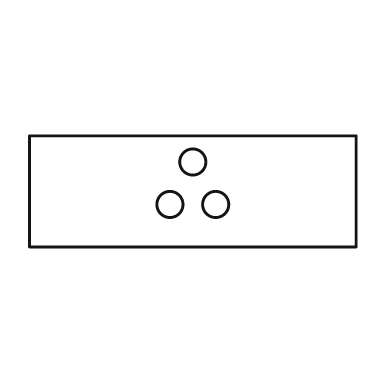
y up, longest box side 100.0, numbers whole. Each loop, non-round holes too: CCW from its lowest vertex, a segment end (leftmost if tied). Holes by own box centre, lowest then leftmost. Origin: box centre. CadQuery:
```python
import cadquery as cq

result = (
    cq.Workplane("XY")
    .moveTo(-50.0, -17.0)
    .lineTo(50.0, -17.0)
    .lineTo(50.0, 17.0)
    .lineTo(-50.0, 17.0)
    .close()
    .moveTo(-7.0, -4.0)
    .circle(4.0)
    .moveTo(7.0, -4.0)
    .circle(4.0)
    .moveTo(0.0, 9.0)
    .circle(4.0)
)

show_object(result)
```